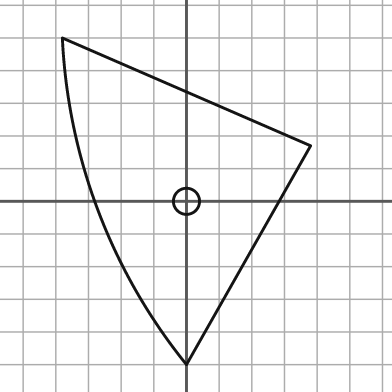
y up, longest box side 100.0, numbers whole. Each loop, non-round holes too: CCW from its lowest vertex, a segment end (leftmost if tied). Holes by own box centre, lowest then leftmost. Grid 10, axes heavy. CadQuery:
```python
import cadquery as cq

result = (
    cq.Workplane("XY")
    .moveTo(0.0, -50.0)
    .lineTo(38.0, 17.0)
    .lineTo(-38.0, 50.0)
    .threePointArc((-27.0, -3.0), (0.0, -50.0))
    .close()
    .moveTo(0.0, 0.0)
    .circle(4.0)
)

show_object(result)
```